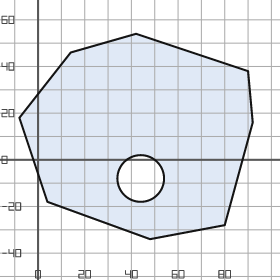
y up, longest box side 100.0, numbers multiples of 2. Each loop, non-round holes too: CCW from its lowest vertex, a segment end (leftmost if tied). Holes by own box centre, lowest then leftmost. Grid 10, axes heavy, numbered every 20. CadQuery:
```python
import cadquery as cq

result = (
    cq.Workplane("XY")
    .moveTo(48.0, -34.0)
    .lineTo(80.0, -28.0)
    .lineTo(92.0, 16.0)
    .lineTo(90.0, 38.0)
    .lineTo(42.0, 54.0)
    .lineTo(14.0, 46.0)
    .lineTo(-8.0, 18.0)
    .lineTo(4.0, -18.0)
    .close()
    .moveTo(44.0, -8.0)
    .circle(10.0)
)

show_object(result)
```